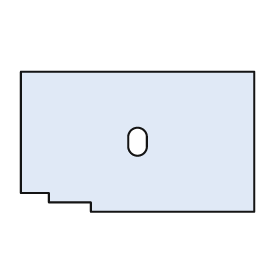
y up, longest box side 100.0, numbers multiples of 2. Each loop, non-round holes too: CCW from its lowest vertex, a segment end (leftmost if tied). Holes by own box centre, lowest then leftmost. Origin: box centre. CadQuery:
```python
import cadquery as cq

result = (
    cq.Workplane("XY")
    .moveTo(-20.0, -30.0)
    .lineTo(50.0, -30.0)
    .lineTo(50.0, 30.0)
    .lineTo(-50.0, 30.0)
    .lineTo(-50.0, -22.0)
    .lineTo(-38.0, -22.0)
    .lineTo(-38.0, -26.0)
    .lineTo(-20.0, -26.0)
    .close()
    .moveTo(-4.0, -2.0)
    .threePointArc((0.0, -6.0), (4.0, -2.0))
    .lineTo(4.0, 2.0)
    .threePointArc((0.0, 6.0), (-4.0, 2.0))
    .close()
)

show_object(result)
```